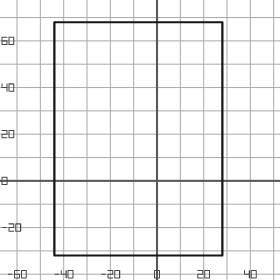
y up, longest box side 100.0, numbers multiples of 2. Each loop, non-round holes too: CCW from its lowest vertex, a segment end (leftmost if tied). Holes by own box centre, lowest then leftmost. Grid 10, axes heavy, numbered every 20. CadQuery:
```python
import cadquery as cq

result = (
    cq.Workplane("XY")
    .moveTo(-44.0, -32.0)
    .lineTo(28.0, -32.0)
    .lineTo(28.0, 68.0)
    .lineTo(-44.0, 68.0)
    .close()
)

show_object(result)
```